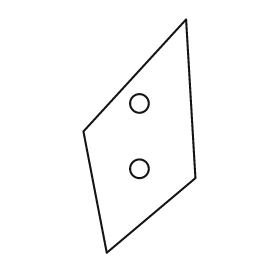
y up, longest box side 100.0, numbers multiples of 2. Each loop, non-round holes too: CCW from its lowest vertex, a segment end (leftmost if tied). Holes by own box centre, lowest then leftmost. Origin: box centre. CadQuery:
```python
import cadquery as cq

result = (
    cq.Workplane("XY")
    .moveTo(-14.0, -50.0)
    .lineTo(24.0, -18.0)
    .lineTo(20.0, 50.0)
    .lineTo(-24.0, 2.0)
    .close()
    .moveTo(0.0, -14.0)
    .circle(4.0)
    .moveTo(0.0, 14.0)
    .circle(4.0)
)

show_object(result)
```